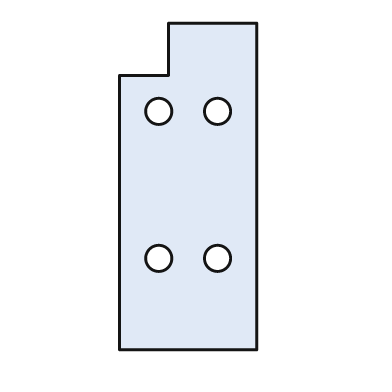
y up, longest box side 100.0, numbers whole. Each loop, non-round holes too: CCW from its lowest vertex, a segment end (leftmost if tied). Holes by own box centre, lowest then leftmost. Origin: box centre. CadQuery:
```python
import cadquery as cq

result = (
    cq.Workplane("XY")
    .moveTo(-21.0, -50.0)
    .lineTo(21.0, -50.0)
    .lineTo(21.0, 50.0)
    .lineTo(-6.0, 50.0)
    .lineTo(-6.0, 34.0)
    .lineTo(-21.0, 34.0)
    .close()
    .moveTo(-9.0, -22.0)
    .circle(4.0)
    .moveTo(9.0, -22.0)
    .circle(4.0)
    .moveTo(-9.0, 23.0)
    .circle(4.0)
    .moveTo(9.0, 23.0)
    .circle(4.0)
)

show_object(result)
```